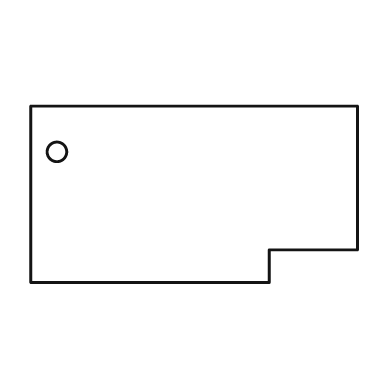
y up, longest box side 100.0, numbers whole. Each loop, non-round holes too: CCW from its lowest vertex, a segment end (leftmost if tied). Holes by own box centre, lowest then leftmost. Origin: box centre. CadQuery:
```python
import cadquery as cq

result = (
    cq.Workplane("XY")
    .moveTo(-50.0, -27.0)
    .lineTo(23.0, -27.0)
    .lineTo(23.0, -17.0)
    .lineTo(50.0, -17.0)
    .lineTo(50.0, 27.0)
    .lineTo(-50.0, 27.0)
    .close()
    .moveTo(-42.0, 13.0)
    .circle(3.0)
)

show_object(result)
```